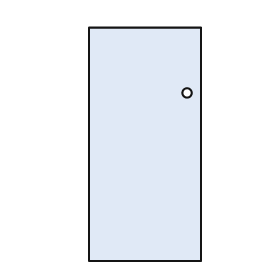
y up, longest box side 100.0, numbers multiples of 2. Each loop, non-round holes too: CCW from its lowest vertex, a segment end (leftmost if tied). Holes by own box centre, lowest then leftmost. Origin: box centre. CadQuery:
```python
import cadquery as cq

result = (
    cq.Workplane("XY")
    .moveTo(-24.0, -50.0)
    .lineTo(24.0, -50.0)
    .lineTo(24.0, 50.0)
    .lineTo(-24.0, 50.0)
    .close()
    .moveTo(18.0, 22.0)
    .circle(2.0)
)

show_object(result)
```